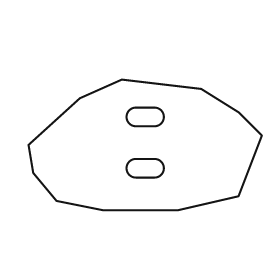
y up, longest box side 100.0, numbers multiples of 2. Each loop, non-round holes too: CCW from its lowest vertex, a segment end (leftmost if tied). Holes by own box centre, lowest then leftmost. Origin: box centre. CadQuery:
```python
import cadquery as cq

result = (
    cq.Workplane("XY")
    .moveTo(-18.0, -28.0)
    .lineTo(14.0, -28.0)
    .lineTo(40.0, -22.0)
    .lineTo(50.0, 4.0)
    .lineTo(40.0, 14.0)
    .lineTo(24.0, 24.0)
    .lineTo(-10.0, 28.0)
    .lineTo(-28.0, 20.0)
    .lineTo(-50.0, 0.0)
    .lineTo(-48.0, -12.0)
    .lineTo(-38.0, -24.0)
    .close()
    .moveTo(-4.0, -14.0)
    .lineTo(4.0, -14.0)
    .threePointArc((8.0, -10.0), (4.0, -6.0))
    .lineTo(-4.0, -6.0)
    .threePointArc((-8.0, -10.0), (-4.0, -14.0))
    .close()
    .moveTo(-4.0, 8.0)
    .lineTo(4.0, 8.0)
    .threePointArc((8.0, 12.0), (4.0, 16.0))
    .lineTo(-4.0, 16.0)
    .threePointArc((-8.0, 12.0), (-4.0, 8.0))
    .close()
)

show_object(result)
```